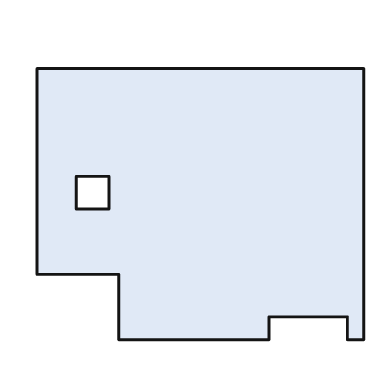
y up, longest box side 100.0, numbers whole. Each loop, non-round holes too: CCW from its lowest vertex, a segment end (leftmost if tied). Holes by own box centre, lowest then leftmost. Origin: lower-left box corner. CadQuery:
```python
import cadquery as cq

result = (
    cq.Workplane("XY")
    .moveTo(25.0, 0.0)
    .lineTo(71.0, 0.0)
    .lineTo(71.0, 7.0)
    .lineTo(95.0, 7.0)
    .lineTo(95.0, 0.0)
    .lineTo(100.0, 0.0)
    .lineTo(100.0, 83.0)
    .lineTo(0.0, 83.0)
    .lineTo(0.0, 20.0)
    .lineTo(25.0, 20.0)
    .close()
    .moveTo(12.0, 40.0)
    .lineTo(22.0, 40.0)
    .lineTo(22.0, 50.0)
    .lineTo(12.0, 50.0)
    .close()
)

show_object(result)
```